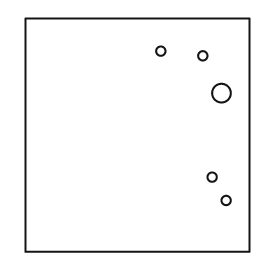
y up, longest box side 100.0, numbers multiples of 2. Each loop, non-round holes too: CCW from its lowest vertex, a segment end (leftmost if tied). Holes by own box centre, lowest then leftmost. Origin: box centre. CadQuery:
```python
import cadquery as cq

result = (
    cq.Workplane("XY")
    .moveTo(-48.0, -50.0)
    .lineTo(48.0, -50.0)
    .lineTo(48.0, 50.0)
    .lineTo(-48.0, 50.0)
    .close()
    .moveTo(38.0, -28.0)
    .circle(2.0)
    .moveTo(32.0, -18.0)
    .circle(2.0)
    .moveTo(36.0, 18.0)
    .circle(4.0)
    .moveTo(28.0, 34.0)
    .circle(2.0)
    .moveTo(10.0, 36.0)
    .circle(2.0)
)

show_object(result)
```